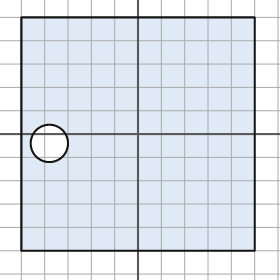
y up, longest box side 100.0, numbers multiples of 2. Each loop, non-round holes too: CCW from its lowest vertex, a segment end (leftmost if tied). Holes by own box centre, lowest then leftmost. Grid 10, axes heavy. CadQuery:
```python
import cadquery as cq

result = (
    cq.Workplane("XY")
    .moveTo(-50.0, -50.0)
    .lineTo(50.0, -50.0)
    .lineTo(50.0, 50.0)
    .lineTo(-50.0, 50.0)
    .close()
    .moveTo(-38.0, -4.0)
    .circle(8.0)
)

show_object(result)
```